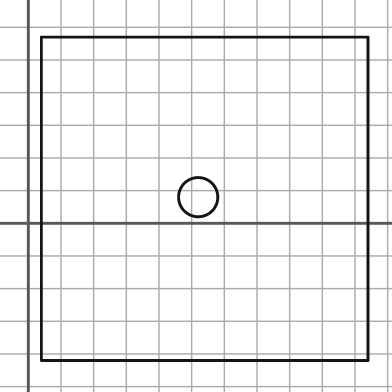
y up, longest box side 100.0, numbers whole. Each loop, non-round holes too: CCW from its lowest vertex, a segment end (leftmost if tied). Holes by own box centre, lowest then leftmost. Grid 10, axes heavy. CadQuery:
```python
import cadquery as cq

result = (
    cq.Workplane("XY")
    .moveTo(4.0, -42.0)
    .lineTo(104.0, -42.0)
    .lineTo(104.0, 57.0)
    .lineTo(4.0, 57.0)
    .close()
    .moveTo(52.0, 8.0)
    .circle(6.0)
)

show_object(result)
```